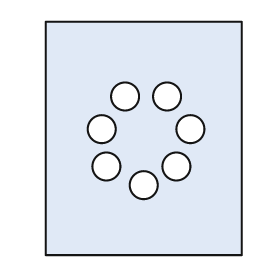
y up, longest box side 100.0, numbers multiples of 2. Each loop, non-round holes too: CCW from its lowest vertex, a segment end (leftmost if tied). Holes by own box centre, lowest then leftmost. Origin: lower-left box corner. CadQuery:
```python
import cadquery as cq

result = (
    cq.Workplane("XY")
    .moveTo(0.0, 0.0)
    .lineTo(84.0, 0.0)
    .lineTo(84.0, 100.0)
    .lineTo(0.0, 100.0)
    .close()
    .moveTo(42.0, 30.0)
    .circle(6.0)
    .moveTo(26.0, 38.0)
    .circle(6.0)
    .moveTo(56.0, 38.0)
    .circle(6.0)
    .moveTo(24.0, 54.0)
    .circle(6.0)
    .moveTo(62.0, 54.0)
    .circle(6.0)
    .moveTo(34.0, 68.0)
    .circle(6.0)
    .moveTo(52.0, 68.0)
    .circle(6.0)
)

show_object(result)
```